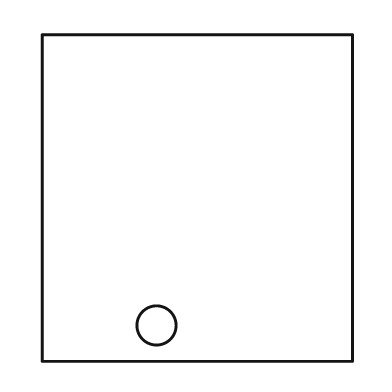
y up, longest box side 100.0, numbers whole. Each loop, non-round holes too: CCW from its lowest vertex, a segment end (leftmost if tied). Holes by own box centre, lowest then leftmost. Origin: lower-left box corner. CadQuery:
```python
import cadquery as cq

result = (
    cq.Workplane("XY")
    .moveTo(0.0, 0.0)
    .lineTo(95.0, 0.0)
    .lineTo(95.0, 100.0)
    .lineTo(0.0, 100.0)
    .close()
    .moveTo(35.0, 11.0)
    .circle(6.0)
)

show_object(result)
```